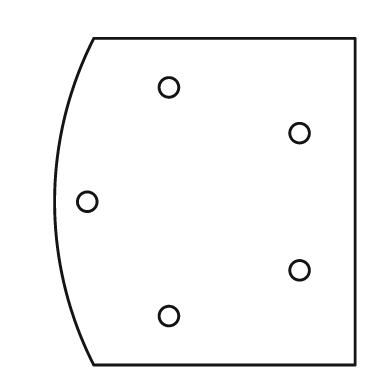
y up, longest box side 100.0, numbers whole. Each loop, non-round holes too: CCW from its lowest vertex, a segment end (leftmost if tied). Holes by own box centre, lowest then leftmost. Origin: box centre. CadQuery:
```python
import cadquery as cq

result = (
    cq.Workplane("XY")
    .moveTo(-34.0, -50.0)
    .lineTo(46.0, -50.0)
    .lineTo(46.0, 50.0)
    .lineTo(-34.0, 50.0)
    .threePointArc((-46.0, 0.0), (-34.0, -50.0))
    .close()
    .moveTo(-11.0, -35.0)
    .circle(3.0)
    .moveTo(29.0, -21.0)
    .circle(3.0)
    .moveTo(-36.0, 0.0)
    .circle(3.0)
    .moveTo(29.0, 21.0)
    .circle(3.0)
    .moveTo(-11.0, 35.0)
    .circle(3.0)
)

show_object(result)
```